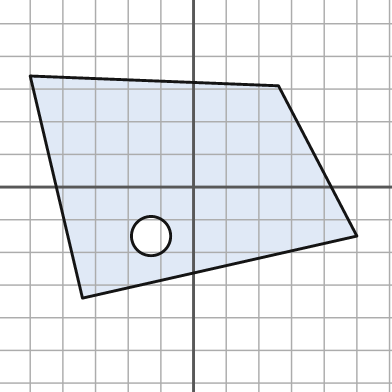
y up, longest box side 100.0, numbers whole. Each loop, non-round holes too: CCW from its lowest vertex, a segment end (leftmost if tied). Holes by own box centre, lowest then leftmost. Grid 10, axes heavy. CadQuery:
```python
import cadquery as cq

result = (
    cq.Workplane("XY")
    .moveTo(-34.0, -34.0)
    .lineTo(50.0, -15.0)
    .lineTo(26.0, 31.0)
    .lineTo(-50.0, 34.0)
    .close()
    .moveTo(-13.0, -15.0)
    .circle(6.0)
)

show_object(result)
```